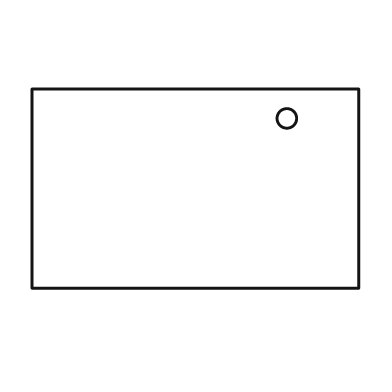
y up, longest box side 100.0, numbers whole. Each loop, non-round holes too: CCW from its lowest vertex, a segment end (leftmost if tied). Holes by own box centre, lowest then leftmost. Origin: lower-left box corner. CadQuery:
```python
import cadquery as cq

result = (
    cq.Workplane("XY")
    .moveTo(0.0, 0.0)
    .lineTo(100.0, 0.0)
    .lineTo(100.0, 61.0)
    .lineTo(0.0, 61.0)
    .close()
    .moveTo(78.0, 52.0)
    .circle(3.0)
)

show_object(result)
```